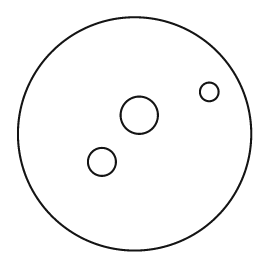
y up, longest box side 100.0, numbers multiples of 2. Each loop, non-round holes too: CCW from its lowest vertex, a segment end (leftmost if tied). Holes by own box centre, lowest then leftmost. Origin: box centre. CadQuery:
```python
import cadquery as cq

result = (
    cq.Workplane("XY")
    .moveTo(0.0, 0.0)
    .circle(50.0)
    .moveTo(-14.0, -12.0)
    .circle(6.0)
    .moveTo(2.0, 8.0)
    .circle(8.0)
    .moveTo(32.0, 18.0)
    .circle(4.0)
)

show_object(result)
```